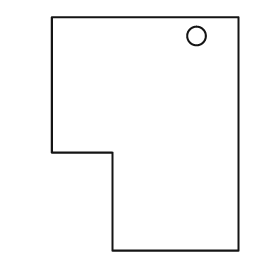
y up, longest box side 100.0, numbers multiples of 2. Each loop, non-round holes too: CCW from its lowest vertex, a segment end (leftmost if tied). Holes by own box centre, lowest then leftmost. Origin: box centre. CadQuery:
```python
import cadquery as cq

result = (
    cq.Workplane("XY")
    .moveTo(-14.0, -50.0)
    .lineTo(40.0, -50.0)
    .lineTo(40.0, 50.0)
    .lineTo(-40.0, 50.0)
    .lineTo(-40.0, -8.0)
    .lineTo(-14.0, -8.0)
    .close()
    .moveTo(22.0, 42.0)
    .circle(4.0)
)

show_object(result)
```